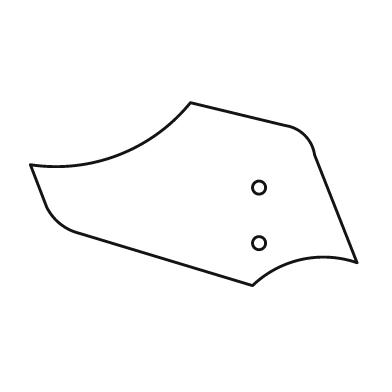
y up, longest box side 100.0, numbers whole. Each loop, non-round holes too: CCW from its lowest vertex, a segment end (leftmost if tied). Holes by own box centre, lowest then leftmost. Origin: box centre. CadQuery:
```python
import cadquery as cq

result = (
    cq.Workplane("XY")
    .moveTo(18.0, -28.0)
    .threePointArc((33.0, -20.0), (50.0, -21.0))
    .lineTo(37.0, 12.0)
    .threePointArc((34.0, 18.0), (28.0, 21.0))
    .lineTo(-1.0, 28.0)
    .threePointArc((-23.0, 12.0), (-50.0, 9.0))
    .lineTo(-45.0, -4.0)
    .threePointArc((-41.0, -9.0), (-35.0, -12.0))
    .close()
    .moveTo(20.0, -15.0)
    .circle(2.0)
    .moveTo(20.0, 2.0)
    .circle(2.0)
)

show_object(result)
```